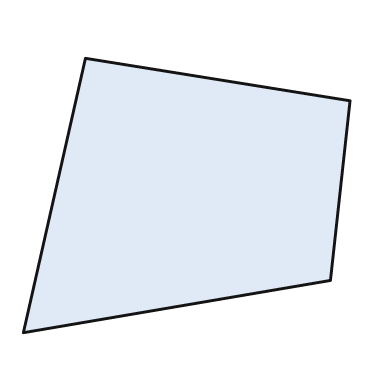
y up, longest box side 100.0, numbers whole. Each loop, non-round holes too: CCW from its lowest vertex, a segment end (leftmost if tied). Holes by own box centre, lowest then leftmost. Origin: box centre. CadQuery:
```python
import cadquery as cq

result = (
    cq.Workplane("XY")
    .moveTo(-50.0, -42.0)
    .lineTo(44.0, -26.0)
    .lineTo(50.0, 29.0)
    .lineTo(-31.0, 42.0)
    .close()
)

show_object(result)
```